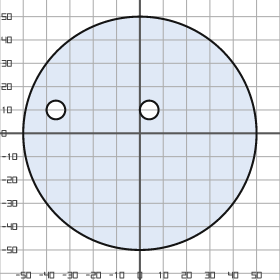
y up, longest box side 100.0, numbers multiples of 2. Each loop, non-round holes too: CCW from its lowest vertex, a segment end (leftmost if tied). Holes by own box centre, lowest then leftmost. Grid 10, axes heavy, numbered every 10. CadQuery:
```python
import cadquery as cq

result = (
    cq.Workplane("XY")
    .moveTo(0.0, 0.0)
    .circle(50.0)
    .moveTo(-36.0, 10.0)
    .circle(4.0)
    .moveTo(4.0, 10.0)
    .circle(4.0)
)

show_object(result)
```